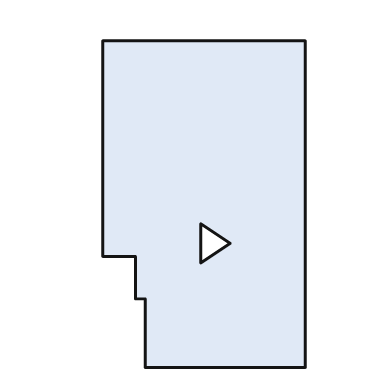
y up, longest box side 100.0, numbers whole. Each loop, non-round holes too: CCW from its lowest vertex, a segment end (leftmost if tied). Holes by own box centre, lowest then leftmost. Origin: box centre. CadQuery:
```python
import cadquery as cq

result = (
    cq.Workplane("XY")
    .moveTo(-18.0, -50.0)
    .lineTo(31.0, -50.0)
    .lineTo(31.0, 50.0)
    .lineTo(-31.0, 50.0)
    .lineTo(-31.0, -16.0)
    .lineTo(-21.0, -16.0)
    .lineTo(-21.0, -29.0)
    .lineTo(-18.0, -29.0)
    .close()
    .moveTo(-1.0, -18.0)
    .lineTo(8.0, -12.0)
    .lineTo(-1.0, -6.0)
    .close()
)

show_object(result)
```